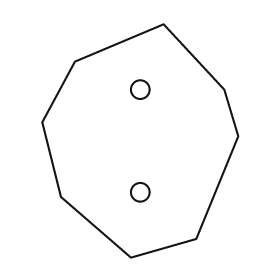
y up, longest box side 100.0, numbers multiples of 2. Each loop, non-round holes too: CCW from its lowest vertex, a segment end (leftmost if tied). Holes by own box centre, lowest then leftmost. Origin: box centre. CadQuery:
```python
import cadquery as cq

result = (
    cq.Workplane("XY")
    .moveTo(-4.0, -50.0)
    .lineTo(24.0, -42.0)
    .lineTo(42.0, 2.0)
    .lineTo(36.0, 22.0)
    .lineTo(10.0, 50.0)
    .lineTo(-28.0, 34.0)
    .lineTo(-42.0, 8.0)
    .lineTo(-34.0, -24.0)
    .close()
    .moveTo(0.0, -22.0)
    .circle(4.0)
    .moveTo(0.0, 22.0)
    .circle(4.0)
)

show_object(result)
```